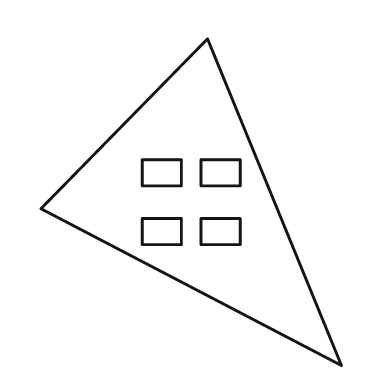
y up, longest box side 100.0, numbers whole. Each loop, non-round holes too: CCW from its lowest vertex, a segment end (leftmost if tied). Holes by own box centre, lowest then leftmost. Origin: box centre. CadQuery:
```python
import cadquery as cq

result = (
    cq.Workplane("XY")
    .moveTo(46.0, -50.0)
    .lineTo(5.0, 50.0)
    .lineTo(-46.0, -2.0)
    .close()
    .moveTo(-15.0, -13.0)
    .lineTo(-3.0, -13.0)
    .lineTo(-3.0, -5.0)
    .lineTo(-15.0, -5.0)
    .close()
    .moveTo(3.0, -13.0)
    .lineTo(15.0, -13.0)
    .lineTo(15.0, -5.0)
    .lineTo(3.0, -5.0)
    .close()
    .moveTo(-15.0, 5.0)
    .lineTo(-3.0, 5.0)
    .lineTo(-3.0, 13.0)
    .lineTo(-15.0, 13.0)
    .close()
    .moveTo(3.0, 5.0)
    .lineTo(15.0, 5.0)
    .lineTo(15.0, 13.0)
    .lineTo(3.0, 13.0)
    .close()
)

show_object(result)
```